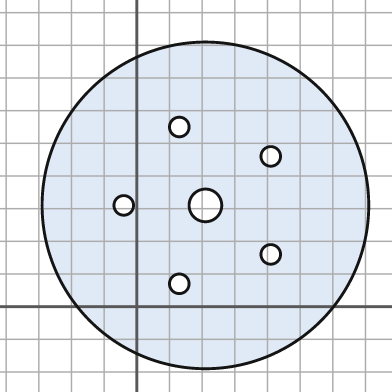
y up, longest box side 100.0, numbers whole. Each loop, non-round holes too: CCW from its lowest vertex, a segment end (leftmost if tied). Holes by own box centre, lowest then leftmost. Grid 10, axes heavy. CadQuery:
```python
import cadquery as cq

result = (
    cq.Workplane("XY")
    .moveTo(21.0, 31.0)
    .circle(50.0)
    .moveTo(13.0, 7.0)
    .circle(3.0)
    .moveTo(41.0, 16.0)
    .circle(3.0)
    .moveTo(-4.0, 31.0)
    .circle(3.0)
    .moveTo(21.0, 31.0)
    .circle(5.0)
    .moveTo(41.0, 46.0)
    .circle(3.0)
    .moveTo(13.0, 55.0)
    .circle(3.0)
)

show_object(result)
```